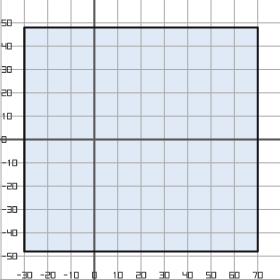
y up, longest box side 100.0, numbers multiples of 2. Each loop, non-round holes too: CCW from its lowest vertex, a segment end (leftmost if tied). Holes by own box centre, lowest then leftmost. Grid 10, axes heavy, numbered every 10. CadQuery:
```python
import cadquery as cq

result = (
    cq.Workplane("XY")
    .moveTo(-30.0, -48.0)
    .lineTo(70.0, -48.0)
    .lineTo(70.0, 48.0)
    .lineTo(-30.0, 48.0)
    .close()
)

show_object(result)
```